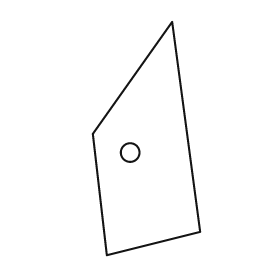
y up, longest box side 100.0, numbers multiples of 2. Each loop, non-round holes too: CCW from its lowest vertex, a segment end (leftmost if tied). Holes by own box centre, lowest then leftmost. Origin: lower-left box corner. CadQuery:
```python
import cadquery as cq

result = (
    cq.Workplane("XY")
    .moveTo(6.0, 0.0)
    .lineTo(46.0, 10.0)
    .lineTo(34.0, 100.0)
    .lineTo(0.0, 52.0)
    .close()
    .moveTo(16.0, 44.0)
    .circle(4.0)
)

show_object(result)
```